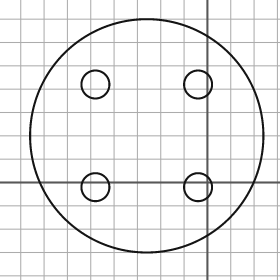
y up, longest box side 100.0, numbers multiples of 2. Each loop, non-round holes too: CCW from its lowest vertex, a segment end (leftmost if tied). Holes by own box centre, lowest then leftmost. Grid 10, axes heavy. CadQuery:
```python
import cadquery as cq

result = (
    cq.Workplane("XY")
    .moveTo(-26.0, 20.0)
    .circle(50.0)
    .moveTo(-48.0, -2.0)
    .circle(6.0)
    .moveTo(-4.0, -2.0)
    .circle(6.0)
    .moveTo(-48.0, 42.0)
    .circle(6.0)
    .moveTo(-4.0, 42.0)
    .circle(6.0)
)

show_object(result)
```